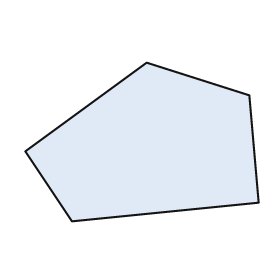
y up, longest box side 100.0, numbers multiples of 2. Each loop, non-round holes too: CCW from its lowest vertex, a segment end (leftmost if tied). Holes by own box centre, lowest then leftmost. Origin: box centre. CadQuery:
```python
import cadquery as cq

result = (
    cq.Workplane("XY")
    .moveTo(-30.0, -34.0)
    .lineTo(50.0, -26.0)
    .lineTo(46.0, 20.0)
    .lineTo(2.0, 34.0)
    .lineTo(-50.0, -4.0)
    .close()
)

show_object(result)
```